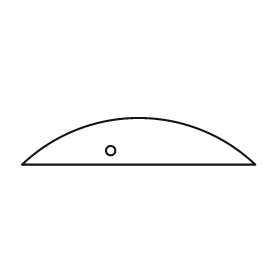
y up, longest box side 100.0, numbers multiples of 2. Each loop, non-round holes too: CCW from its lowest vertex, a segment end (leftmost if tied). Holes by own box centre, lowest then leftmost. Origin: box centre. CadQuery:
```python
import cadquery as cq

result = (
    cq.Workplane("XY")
    .moveTo(-50.0, -10.0)
    .lineTo(50.0, -10.0)
    .threePointArc((0.0, 10.0), (-50.0, -10.0))
    .close()
    .moveTo(-12.0, -4.0)
    .circle(2.0)
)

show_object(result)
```